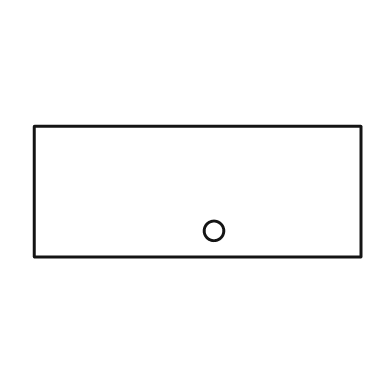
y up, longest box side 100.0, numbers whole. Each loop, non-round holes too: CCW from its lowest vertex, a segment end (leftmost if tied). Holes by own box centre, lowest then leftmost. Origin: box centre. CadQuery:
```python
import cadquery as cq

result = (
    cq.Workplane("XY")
    .moveTo(-50.0, -20.0)
    .lineTo(50.0, -20.0)
    .lineTo(50.0, 20.0)
    .lineTo(-50.0, 20.0)
    .close()
    .moveTo(5.0, -12.0)
    .circle(3.0)
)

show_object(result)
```